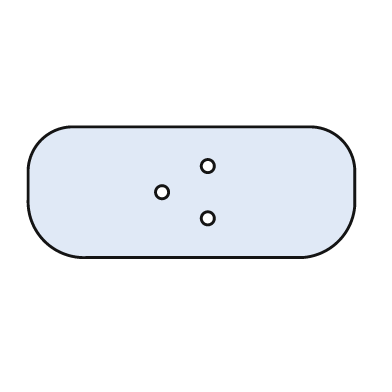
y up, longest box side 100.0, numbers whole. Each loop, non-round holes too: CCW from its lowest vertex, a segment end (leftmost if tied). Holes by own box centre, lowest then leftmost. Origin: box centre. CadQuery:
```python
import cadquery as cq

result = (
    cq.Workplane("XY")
    .moveTo(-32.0, -20.0)
    .lineTo(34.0, -20.0)
    .threePointArc((45.0, -15.0), (50.0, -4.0))
    .lineTo(50.0, 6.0)
    .threePointArc((46.0, 16.0), (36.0, 20.0))
    .lineTo(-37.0, 20.0)
    .threePointArc((-46.0, 16.0), (-50.0, 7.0))
    .lineTo(-50.0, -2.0)
    .threePointArc((-45.0, -15.0), (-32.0, -20.0))
    .close()
    .moveTo(5.0, -8.0)
    .circle(2.0)
    .moveTo(-9.0, 0.0)
    .circle(2.0)
    .moveTo(5.0, 8.0)
    .circle(2.0)
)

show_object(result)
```